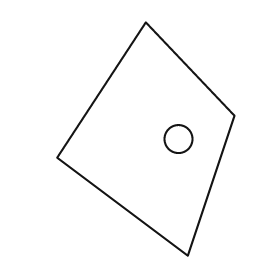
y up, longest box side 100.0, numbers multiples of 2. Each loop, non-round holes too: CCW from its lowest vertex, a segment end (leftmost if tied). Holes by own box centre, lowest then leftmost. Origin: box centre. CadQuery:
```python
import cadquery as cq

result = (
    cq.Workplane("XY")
    .moveTo(18.0, -50.0)
    .lineTo(38.0, 10.0)
    .lineTo(0.0, 50.0)
    .lineTo(-38.0, -8.0)
    .close()
    .moveTo(14.0, 0.0)
    .circle(6.0)
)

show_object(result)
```